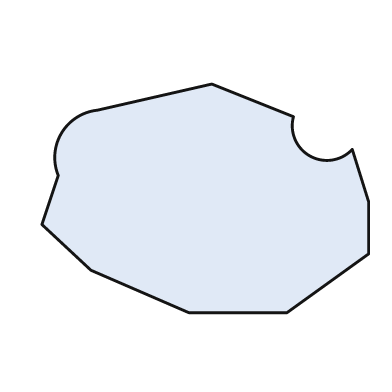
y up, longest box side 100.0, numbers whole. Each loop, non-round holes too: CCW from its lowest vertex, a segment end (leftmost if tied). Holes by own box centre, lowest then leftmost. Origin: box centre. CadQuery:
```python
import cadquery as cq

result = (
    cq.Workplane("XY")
    .moveTo(-5.0, -35.0)
    .lineTo(25.0, -35.0)
    .lineTo(50.0, -17.0)
    .lineTo(50.0, -1.0)
    .lineTo(45.0, 15.0)
    .threePointArc((32.0, 13.0), (27.0, 25.0))
    .lineTo(2.0, 35.0)
    .lineTo(-33.0, 27.0)
    .threePointArc((-44.0, 20.0), (-45.0, 7.0))
    .lineTo(-50.0, -8.0)
    .lineTo(-35.0, -22.0)
    .close()
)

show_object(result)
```